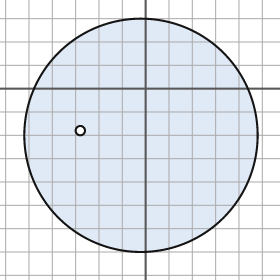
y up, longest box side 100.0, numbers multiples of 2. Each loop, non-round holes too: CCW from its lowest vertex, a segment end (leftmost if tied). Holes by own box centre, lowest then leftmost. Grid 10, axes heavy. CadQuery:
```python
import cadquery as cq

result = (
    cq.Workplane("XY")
    .moveTo(-2.0, -20.0)
    .circle(50.0)
    .moveTo(-28.0, -18.0)
    .circle(2.0)
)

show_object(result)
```